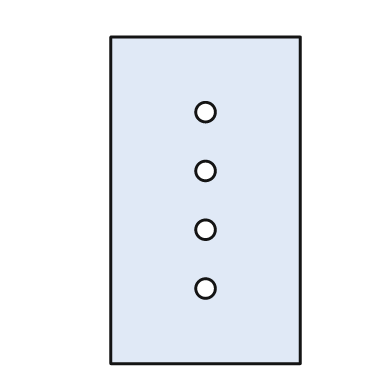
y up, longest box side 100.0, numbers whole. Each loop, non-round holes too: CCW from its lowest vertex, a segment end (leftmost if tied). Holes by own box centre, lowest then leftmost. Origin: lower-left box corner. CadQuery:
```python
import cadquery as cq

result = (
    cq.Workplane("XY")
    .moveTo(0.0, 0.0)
    .lineTo(58.0, 0.0)
    .lineTo(58.0, 100.0)
    .lineTo(0.0, 100.0)
    .close()
    .moveTo(29.0, 23.0)
    .circle(3.0)
    .moveTo(29.0, 41.0)
    .circle(3.0)
    .moveTo(29.0, 59.0)
    .circle(3.0)
    .moveTo(29.0, 77.0)
    .circle(3.0)
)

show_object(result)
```